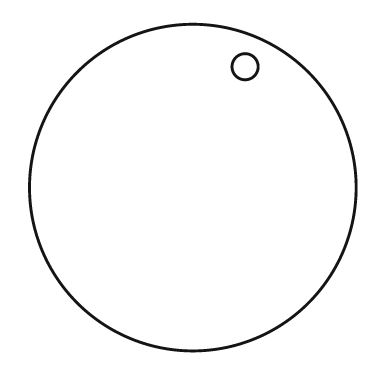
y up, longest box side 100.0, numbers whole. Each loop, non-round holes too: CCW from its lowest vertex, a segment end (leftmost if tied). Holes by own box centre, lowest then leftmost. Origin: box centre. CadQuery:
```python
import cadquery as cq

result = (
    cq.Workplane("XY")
    .moveTo(0.0, 0.0)
    .circle(50.0)
    .moveTo(16.0, 37.0)
    .circle(4.0)
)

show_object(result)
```